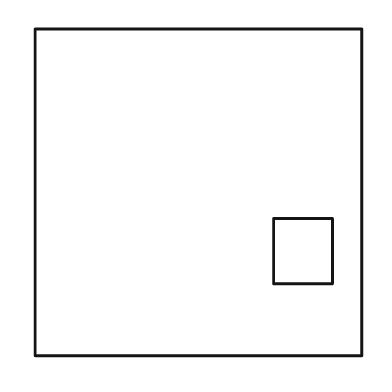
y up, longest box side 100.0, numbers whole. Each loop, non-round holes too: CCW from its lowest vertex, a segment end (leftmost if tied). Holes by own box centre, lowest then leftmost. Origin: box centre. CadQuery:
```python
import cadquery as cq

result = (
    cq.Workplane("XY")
    .moveTo(-50.0, -50.0)
    .lineTo(50.0, -50.0)
    .lineTo(50.0, 50.0)
    .lineTo(-50.0, 50.0)
    .close()
    .moveTo(23.0, -28.0)
    .lineTo(41.0, -28.0)
    .lineTo(41.0, -8.0)
    .lineTo(23.0, -8.0)
    .close()
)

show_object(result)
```